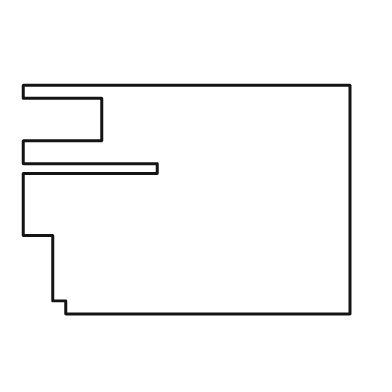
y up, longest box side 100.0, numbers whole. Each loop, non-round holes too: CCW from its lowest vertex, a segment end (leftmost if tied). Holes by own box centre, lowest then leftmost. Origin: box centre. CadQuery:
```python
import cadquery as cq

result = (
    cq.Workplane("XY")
    .moveTo(-37.0, -35.0)
    .lineTo(50.0, -35.0)
    .lineTo(50.0, 35.0)
    .lineTo(-50.0, 35.0)
    .lineTo(-50.0, 31.0)
    .lineTo(-26.0, 31.0)
    .lineTo(-26.0, 18.0)
    .lineTo(-50.0, 18.0)
    .lineTo(-50.0, 11.0)
    .lineTo(-9.0, 11.0)
    .lineTo(-9.0, 8.0)
    .lineTo(-50.0, 8.0)
    .lineTo(-50.0, -11.0)
    .lineTo(-41.0, -11.0)
    .lineTo(-41.0, -31.0)
    .lineTo(-37.0, -31.0)
    .close()
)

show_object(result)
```